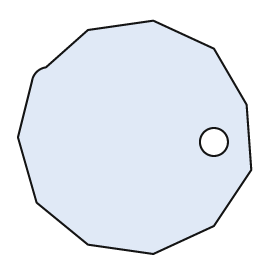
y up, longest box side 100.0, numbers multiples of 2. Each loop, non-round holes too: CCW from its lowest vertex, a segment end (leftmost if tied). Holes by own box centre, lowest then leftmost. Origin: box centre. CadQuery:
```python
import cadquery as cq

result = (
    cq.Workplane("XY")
    .moveTo(8.0, -50.0)
    .lineTo(34.0, -38.0)
    .lineTo(50.0, -14.0)
    .lineTo(48.0, 14.0)
    .lineTo(34.0, 38.0)
    .lineTo(8.0, 50.0)
    .lineTo(-20.0, 46.0)
    .lineTo(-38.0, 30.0)
    .threePointArc((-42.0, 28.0), (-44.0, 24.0))
    .lineTo(-50.0, 0.0)
    .lineTo(-42.0, -28.0)
    .lineTo(-20.0, -46.0)
    .close()
    .moveTo(34.0, -2.0)
    .circle(6.0)
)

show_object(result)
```